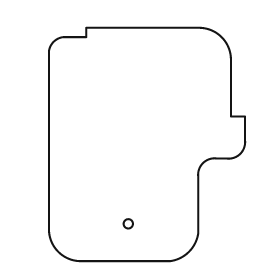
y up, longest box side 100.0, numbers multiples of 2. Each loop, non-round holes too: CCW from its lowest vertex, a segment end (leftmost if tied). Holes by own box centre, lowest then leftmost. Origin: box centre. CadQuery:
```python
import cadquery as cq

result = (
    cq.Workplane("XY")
    .moveTo(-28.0, -50.0)
    .lineTo(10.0, -50.0)
    .threePointArc((18.0, -46.0), (22.0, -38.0))
    .lineTo(22.0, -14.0)
    .threePointArc((24.0, -8.0), (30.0, -6.0))
    .lineTo(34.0, -6.0)
    .threePointArc((40.0, -4.0), (42.0, 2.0))
    .lineTo(42.0, 12.0)
    .lineTo(36.0, 12.0)
    .lineTo(36.0, 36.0)
    .threePointArc((32.0, 46.0), (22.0, 50.0))
    .lineTo(-26.0, 50.0)
    .lineTo(-26.0, 46.0)
    .lineTo(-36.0, 46.0)
    .threePointArc((-40.0, 44.0), (-42.0, 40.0))
    .lineTo(-42.0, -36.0)
    .threePointArc((-38.0, -46.0), (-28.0, -50.0))
    .close()
    .moveTo(-8.0, -34.0)
    .circle(2.0)
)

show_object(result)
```